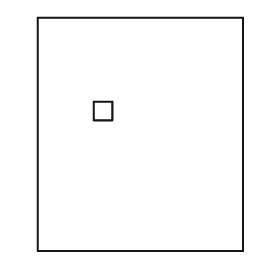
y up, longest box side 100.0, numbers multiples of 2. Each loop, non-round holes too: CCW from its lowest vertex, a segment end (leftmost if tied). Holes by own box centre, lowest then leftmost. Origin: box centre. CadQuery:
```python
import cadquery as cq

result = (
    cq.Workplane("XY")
    .moveTo(-44.0, -50.0)
    .lineTo(44.0, -50.0)
    .lineTo(44.0, 50.0)
    .lineTo(-44.0, 50.0)
    .close()
    .moveTo(-20.0, 6.0)
    .lineTo(-12.0, 6.0)
    .lineTo(-12.0, 14.0)
    .lineTo(-20.0, 14.0)
    .close()
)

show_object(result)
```